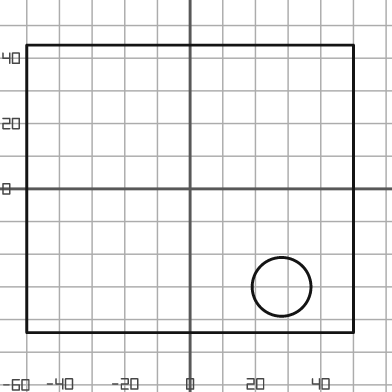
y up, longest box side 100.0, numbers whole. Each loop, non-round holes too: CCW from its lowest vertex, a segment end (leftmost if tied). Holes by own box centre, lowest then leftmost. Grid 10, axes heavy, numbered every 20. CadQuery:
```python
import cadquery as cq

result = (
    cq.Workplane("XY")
    .moveTo(-50.0, -44.0)
    .lineTo(50.0, -44.0)
    .lineTo(50.0, 44.0)
    .lineTo(-50.0, 44.0)
    .close()
    .moveTo(28.0, -30.0)
    .circle(9.0)
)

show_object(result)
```